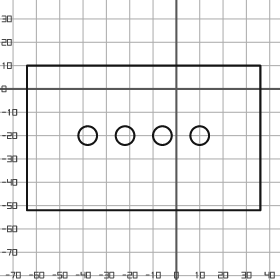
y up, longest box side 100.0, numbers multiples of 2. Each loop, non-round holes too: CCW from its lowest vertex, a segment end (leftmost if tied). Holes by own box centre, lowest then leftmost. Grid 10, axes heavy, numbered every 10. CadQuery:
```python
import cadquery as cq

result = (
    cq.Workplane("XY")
    .moveTo(-64.0, -52.0)
    .lineTo(36.0, -52.0)
    .lineTo(36.0, 10.0)
    .lineTo(-64.0, 10.0)
    .close()
    .moveTo(-38.0, -20.0)
    .circle(4.0)
    .moveTo(-22.0, -20.0)
    .circle(4.0)
    .moveTo(-6.0, -20.0)
    .circle(4.0)
    .moveTo(10.0, -20.0)
    .circle(4.0)
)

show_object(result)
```